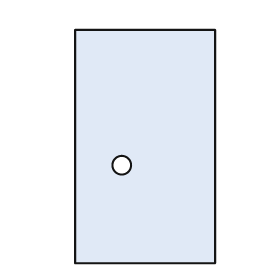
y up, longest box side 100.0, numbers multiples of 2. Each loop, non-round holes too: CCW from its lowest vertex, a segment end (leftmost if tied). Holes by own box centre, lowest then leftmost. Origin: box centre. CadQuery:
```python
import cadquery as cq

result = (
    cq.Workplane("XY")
    .moveTo(-30.0, -50.0)
    .lineTo(30.0, -50.0)
    .lineTo(30.0, 50.0)
    .lineTo(-30.0, 50.0)
    .close()
    .moveTo(-10.0, -8.0)
    .circle(4.0)
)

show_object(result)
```